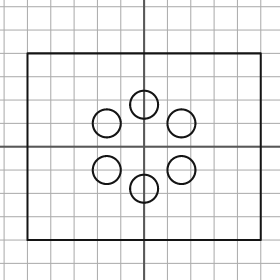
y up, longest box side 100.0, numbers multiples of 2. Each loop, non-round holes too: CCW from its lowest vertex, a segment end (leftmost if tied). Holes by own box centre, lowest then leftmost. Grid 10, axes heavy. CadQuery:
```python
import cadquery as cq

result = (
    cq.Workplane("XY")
    .moveTo(-50.0, -40.0)
    .lineTo(50.0, -40.0)
    .lineTo(50.0, 40.0)
    .lineTo(-50.0, 40.0)
    .close()
    .moveTo(0.0, -18.0)
    .circle(6.0)
    .moveTo(-16.0, -10.0)
    .circle(6.0)
    .moveTo(16.0, -10.0)
    .circle(6.0)
    .moveTo(-16.0, 10.0)
    .circle(6.0)
    .moveTo(16.0, 10.0)
    .circle(6.0)
    .moveTo(0.0, 18.0)
    .circle(6.0)
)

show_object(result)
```